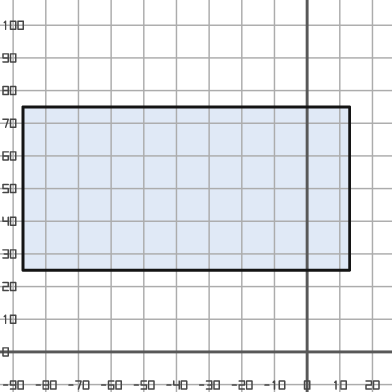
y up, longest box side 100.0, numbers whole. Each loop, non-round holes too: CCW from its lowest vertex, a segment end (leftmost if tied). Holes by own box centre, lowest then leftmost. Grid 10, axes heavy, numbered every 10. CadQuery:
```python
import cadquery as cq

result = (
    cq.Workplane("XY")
    .moveTo(-87.0, 25.0)
    .lineTo(13.0, 25.0)
    .lineTo(13.0, 75.0)
    .lineTo(-87.0, 75.0)
    .close()
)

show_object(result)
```